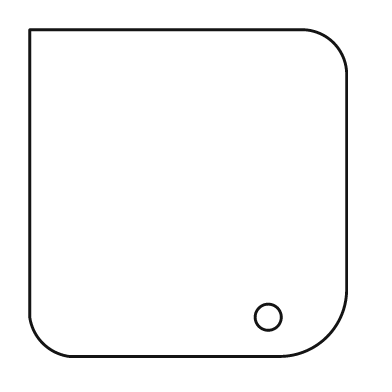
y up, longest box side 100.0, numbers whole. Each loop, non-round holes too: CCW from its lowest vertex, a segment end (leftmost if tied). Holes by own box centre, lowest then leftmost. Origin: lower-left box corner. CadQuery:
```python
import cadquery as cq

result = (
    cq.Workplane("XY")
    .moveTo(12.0, 0.0)
    .lineTo(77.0, 0.0)
    .threePointArc((91.0, 6.0), (97.0, 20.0))
    .lineTo(97.0, 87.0)
    .threePointArc((93.0, 96.0), (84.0, 100.0))
    .lineTo(0.0, 100.0)
    .lineTo(0.0, 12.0)
    .threePointArc((4.0, 4.0), (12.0, 0.0))
    .close()
    .moveTo(73.0, 12.0)
    .circle(4.0)
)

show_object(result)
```